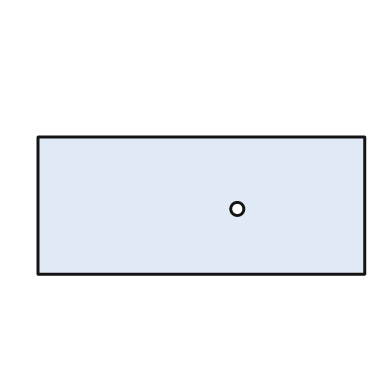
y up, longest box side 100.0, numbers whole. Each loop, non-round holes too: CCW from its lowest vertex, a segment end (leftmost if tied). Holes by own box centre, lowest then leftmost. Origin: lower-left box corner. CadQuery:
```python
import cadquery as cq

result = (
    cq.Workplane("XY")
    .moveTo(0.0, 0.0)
    .lineTo(100.0, 0.0)
    .lineTo(100.0, 42.0)
    .lineTo(0.0, 42.0)
    .close()
    .moveTo(61.0, 20.0)
    .circle(2.0)
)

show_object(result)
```